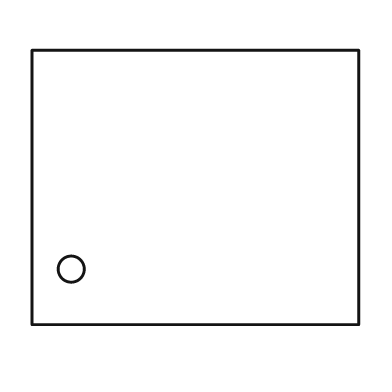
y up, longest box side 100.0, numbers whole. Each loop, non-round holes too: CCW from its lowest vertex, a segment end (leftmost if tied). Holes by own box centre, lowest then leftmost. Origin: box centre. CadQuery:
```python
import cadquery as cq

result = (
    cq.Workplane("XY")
    .moveTo(-50.0, -42.0)
    .lineTo(50.0, -42.0)
    .lineTo(50.0, 42.0)
    .lineTo(-50.0, 42.0)
    .close()
    .moveTo(-38.0, -25.0)
    .circle(4.0)
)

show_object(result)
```